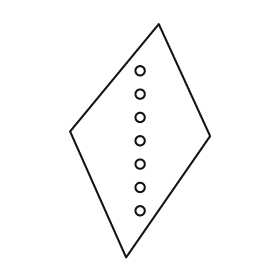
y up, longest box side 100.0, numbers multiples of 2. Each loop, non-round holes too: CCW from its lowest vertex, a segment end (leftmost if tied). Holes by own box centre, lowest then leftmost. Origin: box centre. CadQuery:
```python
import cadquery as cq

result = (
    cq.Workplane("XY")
    .moveTo(-6.0, -50.0)
    .lineTo(30.0, 2.0)
    .lineTo(8.0, 50.0)
    .lineTo(-30.0, 4.0)
    .close()
    .moveTo(0.0, -30.0)
    .circle(2.0)
    .moveTo(0.0, -20.0)
    .circle(2.0)
    .moveTo(0.0, -10.0)
    .circle(2.0)
    .moveTo(0.0, 0.0)
    .circle(2.0)
    .moveTo(0.0, 10.0)
    .circle(2.0)
    .moveTo(0.0, 20.0)
    .circle(2.0)
    .moveTo(0.0, 30.0)
    .circle(2.0)
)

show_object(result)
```